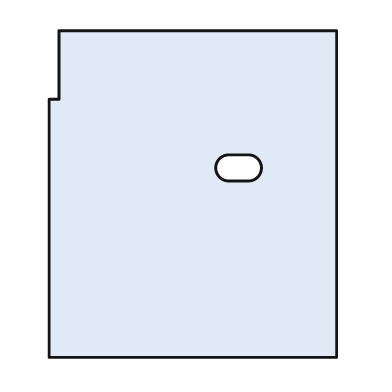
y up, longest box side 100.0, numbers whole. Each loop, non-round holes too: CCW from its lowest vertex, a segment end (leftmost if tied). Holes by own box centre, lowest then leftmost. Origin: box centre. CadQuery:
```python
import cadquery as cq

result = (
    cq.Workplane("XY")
    .moveTo(-44.0, -50.0)
    .lineTo(44.0, -50.0)
    .lineTo(44.0, 50.0)
    .lineTo(-41.0, 50.0)
    .lineTo(-41.0, 29.0)
    .lineTo(-44.0, 29.0)
    .close()
    .moveTo(11.0, 4.0)
    .lineTo(17.0, 4.0)
    .threePointArc((21.0, 8.0), (17.0, 12.0))
    .lineTo(11.0, 12.0)
    .threePointArc((7.0, 8.0), (11.0, 4.0))
    .close()
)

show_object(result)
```